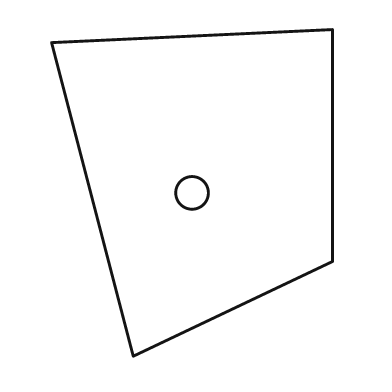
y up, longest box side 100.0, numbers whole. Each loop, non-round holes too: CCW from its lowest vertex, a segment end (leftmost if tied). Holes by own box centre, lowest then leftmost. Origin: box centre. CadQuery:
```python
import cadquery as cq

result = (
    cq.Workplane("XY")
    .moveTo(-18.0, -50.0)
    .lineTo(43.0, -21.0)
    .lineTo(43.0, 50.0)
    .lineTo(-43.0, 46.0)
    .close()
    .moveTo(0.0, 0.0)
    .circle(5.0)
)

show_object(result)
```